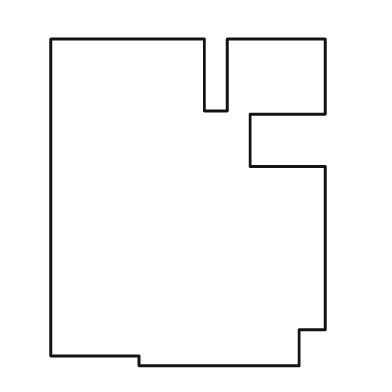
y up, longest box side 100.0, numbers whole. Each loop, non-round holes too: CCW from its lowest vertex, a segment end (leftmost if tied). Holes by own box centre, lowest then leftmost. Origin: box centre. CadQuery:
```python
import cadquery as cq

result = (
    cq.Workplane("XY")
    .moveTo(-15.0, -50.0)
    .lineTo(34.0, -50.0)
    .lineTo(34.0, -39.0)
    .lineTo(42.0, -39.0)
    .lineTo(42.0, 11.0)
    .lineTo(19.0, 11.0)
    .lineTo(19.0, 27.0)
    .lineTo(42.0, 27.0)
    .lineTo(42.0, 50.0)
    .lineTo(12.0, 50.0)
    .lineTo(12.0, 28.0)
    .lineTo(5.0, 28.0)
    .lineTo(5.0, 50.0)
    .lineTo(-42.0, 50.0)
    .lineTo(-42.0, -47.0)
    .lineTo(-15.0, -47.0)
    .close()
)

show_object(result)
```